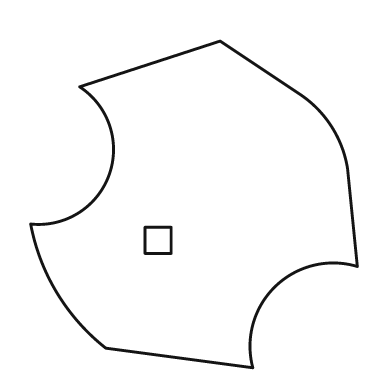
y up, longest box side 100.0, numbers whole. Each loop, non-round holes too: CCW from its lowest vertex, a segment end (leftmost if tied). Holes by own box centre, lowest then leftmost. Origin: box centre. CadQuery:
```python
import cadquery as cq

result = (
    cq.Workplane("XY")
    .moveTo(18.0, -50.0)
    .threePointArc((25.0, -25.0), (50.0, -19.0))
    .lineTo(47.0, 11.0)
    .threePointArc((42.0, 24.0), (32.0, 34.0))
    .lineTo(8.0, 50.0)
    .lineTo(-35.0, 36.0)
    .threePointArc((-26.0, 9.0), (-50.0, -6.0))
    .threePointArc((-42.0, -27.0), (-27.0, -44.0))
    .close()
    .moveTo(-15.0, -15.0)
    .lineTo(-7.0, -15.0)
    .lineTo(-7.0, -7.0)
    .lineTo(-15.0, -7.0)
    .close()
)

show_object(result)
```